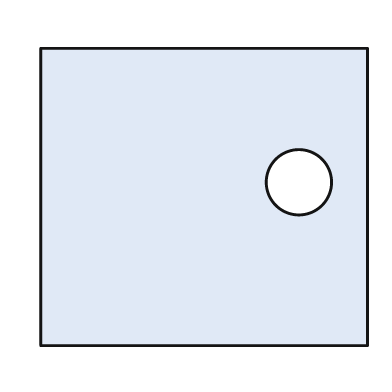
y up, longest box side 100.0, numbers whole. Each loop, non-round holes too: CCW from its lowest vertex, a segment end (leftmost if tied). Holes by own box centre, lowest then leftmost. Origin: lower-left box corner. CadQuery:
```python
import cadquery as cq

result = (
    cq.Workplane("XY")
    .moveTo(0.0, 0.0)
    .lineTo(100.0, 0.0)
    .lineTo(100.0, 91.0)
    .lineTo(0.0, 91.0)
    .close()
    .moveTo(79.0, 50.0)
    .circle(10.0)
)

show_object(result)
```